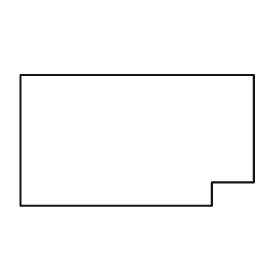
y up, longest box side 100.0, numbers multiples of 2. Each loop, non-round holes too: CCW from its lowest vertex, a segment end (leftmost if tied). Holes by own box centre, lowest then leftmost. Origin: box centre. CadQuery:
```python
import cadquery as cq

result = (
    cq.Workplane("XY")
    .moveTo(-50.0, -28.0)
    .lineTo(32.0, -28.0)
    .lineTo(32.0, -18.0)
    .lineTo(50.0, -18.0)
    .lineTo(50.0, 28.0)
    .lineTo(-50.0, 28.0)
    .close()
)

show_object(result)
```